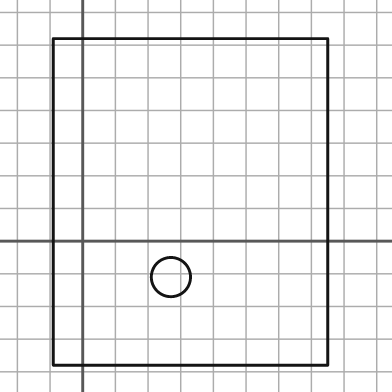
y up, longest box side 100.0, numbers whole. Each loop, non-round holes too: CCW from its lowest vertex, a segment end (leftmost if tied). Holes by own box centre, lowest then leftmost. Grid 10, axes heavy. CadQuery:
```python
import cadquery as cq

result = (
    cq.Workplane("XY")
    .moveTo(-9.0, -38.0)
    .lineTo(75.0, -38.0)
    .lineTo(75.0, 62.0)
    .lineTo(-9.0, 62.0)
    .close()
    .moveTo(27.0, -11.0)
    .circle(6.0)
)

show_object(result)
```